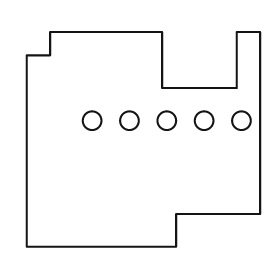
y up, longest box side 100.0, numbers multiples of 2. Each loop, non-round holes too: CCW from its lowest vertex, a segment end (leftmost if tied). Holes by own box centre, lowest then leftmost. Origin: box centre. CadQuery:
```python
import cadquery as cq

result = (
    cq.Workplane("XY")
    .moveTo(-50.0, -46.0)
    .lineTo(14.0, -46.0)
    .lineTo(14.0, -32.0)
    .lineTo(50.0, -32.0)
    .lineTo(50.0, 46.0)
    .lineTo(40.0, 46.0)
    .lineTo(40.0, 22.0)
    .lineTo(8.0, 22.0)
    .lineTo(8.0, 46.0)
    .lineTo(-40.0, 46.0)
    .lineTo(-40.0, 36.0)
    .lineTo(-50.0, 36.0)
    .close()
    .moveTo(-22.0, 8.0)
    .circle(4.0)
    .moveTo(-6.0, 8.0)
    .circle(4.0)
    .moveTo(10.0, 8.0)
    .circle(4.0)
    .moveTo(26.0, 8.0)
    .circle(4.0)
    .moveTo(42.0, 8.0)
    .circle(4.0)
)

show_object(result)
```